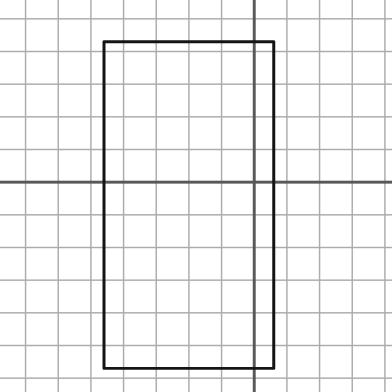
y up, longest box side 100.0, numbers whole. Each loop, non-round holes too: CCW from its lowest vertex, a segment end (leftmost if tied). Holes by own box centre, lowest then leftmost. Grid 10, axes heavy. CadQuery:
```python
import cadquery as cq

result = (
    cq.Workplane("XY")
    .moveTo(-46.0, -57.0)
    .lineTo(6.0, -57.0)
    .lineTo(6.0, 43.0)
    .lineTo(-46.0, 43.0)
    .close()
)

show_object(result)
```